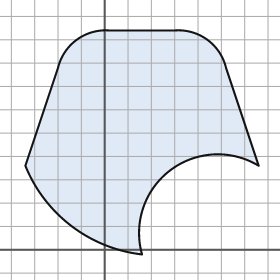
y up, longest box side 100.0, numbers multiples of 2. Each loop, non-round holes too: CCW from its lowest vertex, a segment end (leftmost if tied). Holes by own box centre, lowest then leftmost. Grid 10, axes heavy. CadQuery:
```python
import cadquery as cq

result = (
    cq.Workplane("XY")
    .moveTo(16.0, -2.0)
    .threePointArc((28.0, 34.0), (66.0, 36.0))
    .lineTo(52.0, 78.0)
    .threePointArc((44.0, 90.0), (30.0, 94.0))
    .lineTo(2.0, 94.0)
    .threePointArc((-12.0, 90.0), (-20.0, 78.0))
    .lineTo(-34.0, 36.0)
    .threePointArc((-14.0, 10.0), (16.0, -2.0))
    .close()
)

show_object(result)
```